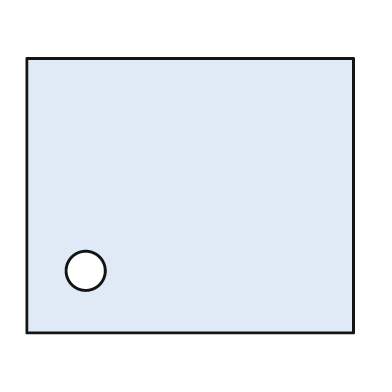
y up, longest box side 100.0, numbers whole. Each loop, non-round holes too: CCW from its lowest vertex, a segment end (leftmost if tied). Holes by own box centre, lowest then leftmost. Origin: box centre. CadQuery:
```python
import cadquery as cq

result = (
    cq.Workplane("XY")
    .moveTo(-50.0, -42.0)
    .lineTo(50.0, -42.0)
    .lineTo(50.0, 42.0)
    .lineTo(-50.0, 42.0)
    .close()
    .moveTo(-32.0, -23.0)
    .circle(6.0)
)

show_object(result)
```